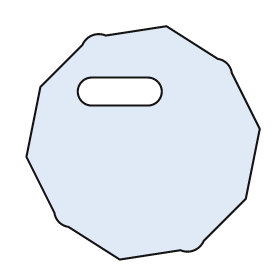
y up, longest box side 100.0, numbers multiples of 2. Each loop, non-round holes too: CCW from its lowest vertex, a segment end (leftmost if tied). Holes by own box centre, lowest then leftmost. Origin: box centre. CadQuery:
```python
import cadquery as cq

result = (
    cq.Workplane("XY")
    .moveTo(-10.0, -50.0)
    .lineTo(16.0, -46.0)
    .threePointArc((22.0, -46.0), (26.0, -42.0))
    .lineTo(44.0, -24.0)
    .lineTo(50.0, 6.0)
    .lineTo(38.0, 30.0)
    .threePointArc((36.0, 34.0), (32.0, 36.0))
    .lineTo(10.0, 50.0)
    .lineTo(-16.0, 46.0)
    .threePointArc((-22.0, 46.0), (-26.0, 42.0))
    .lineTo(-44.0, 24.0)
    .lineTo(-50.0, -6.0)
    .lineTo(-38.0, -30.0)
    .threePointArc((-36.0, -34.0), (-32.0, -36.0))
    .close()
    .moveTo(-22.0, 16.0)
    .lineTo(2.0, 16.0)
    .threePointArc((8.0, 22.0), (2.0, 28.0))
    .lineTo(-22.0, 28.0)
    .threePointArc((-28.0, 22.0), (-22.0, 16.0))
    .close()
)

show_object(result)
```